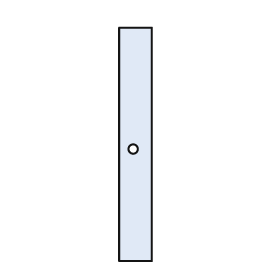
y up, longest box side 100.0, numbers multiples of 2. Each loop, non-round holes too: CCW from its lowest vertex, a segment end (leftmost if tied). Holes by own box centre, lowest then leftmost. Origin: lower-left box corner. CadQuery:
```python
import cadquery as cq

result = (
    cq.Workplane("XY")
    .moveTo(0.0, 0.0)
    .lineTo(14.0, 0.0)
    .lineTo(14.0, 100.0)
    .lineTo(0.0, 100.0)
    .close()
    .moveTo(6.0, 48.0)
    .circle(2.0)
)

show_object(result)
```